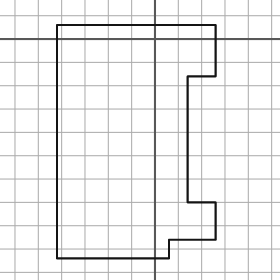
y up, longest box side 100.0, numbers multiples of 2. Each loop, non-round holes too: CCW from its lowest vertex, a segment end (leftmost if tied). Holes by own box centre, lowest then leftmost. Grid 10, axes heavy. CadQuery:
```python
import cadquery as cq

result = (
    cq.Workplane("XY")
    .moveTo(-42.0, -94.0)
    .lineTo(6.0, -94.0)
    .lineTo(6.0, -86.0)
    .lineTo(26.0, -86.0)
    .lineTo(26.0, -70.0)
    .lineTo(14.0, -70.0)
    .lineTo(14.0, -16.0)
    .lineTo(26.0, -16.0)
    .lineTo(26.0, 6.0)
    .lineTo(-42.0, 6.0)
    .close()
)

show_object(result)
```